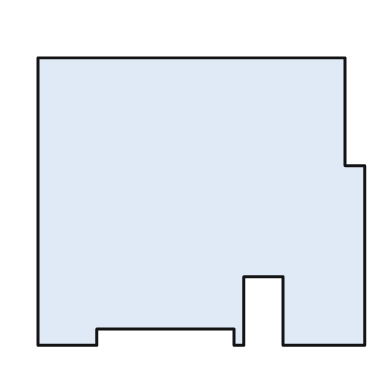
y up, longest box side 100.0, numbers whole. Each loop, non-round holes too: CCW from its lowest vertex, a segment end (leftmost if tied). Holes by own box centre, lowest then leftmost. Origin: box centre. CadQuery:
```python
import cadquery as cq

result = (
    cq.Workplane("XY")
    .moveTo(-50.0, -44.0)
    .lineTo(-32.0, -44.0)
    .lineTo(-32.0, -39.0)
    .lineTo(10.0, -39.0)
    .lineTo(10.0, -44.0)
    .lineTo(13.0, -44.0)
    .lineTo(13.0, -23.0)
    .lineTo(25.0, -23.0)
    .lineTo(25.0, -44.0)
    .lineTo(50.0, -44.0)
    .lineTo(50.0, 11.0)
    .lineTo(44.0, 11.0)
    .lineTo(44.0, 44.0)
    .lineTo(-50.0, 44.0)
    .close()
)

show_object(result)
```